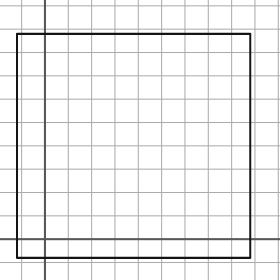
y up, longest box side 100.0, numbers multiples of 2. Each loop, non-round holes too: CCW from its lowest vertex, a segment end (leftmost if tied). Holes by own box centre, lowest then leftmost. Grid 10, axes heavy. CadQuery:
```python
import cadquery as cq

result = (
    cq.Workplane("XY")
    .moveTo(-12.0, -8.0)
    .lineTo(88.0, -8.0)
    .lineTo(88.0, 88.0)
    .lineTo(-12.0, 88.0)
    .close()
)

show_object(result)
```